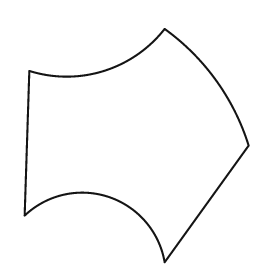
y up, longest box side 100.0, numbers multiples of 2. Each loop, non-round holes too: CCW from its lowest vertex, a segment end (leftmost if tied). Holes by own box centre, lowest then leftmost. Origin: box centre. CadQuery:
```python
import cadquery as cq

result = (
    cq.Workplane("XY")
    .moveTo(12.0, -50.0)
    .lineTo(48.0, 0.0)
    .threePointArc((34.0, 28.0), (12.0, 50.0))
    .threePointArc((-14.0, 32.0), (-46.0, 32.0))
    .lineTo(-48.0, -30.0)
    .threePointArc((-12.0, -22.0), (12.0, -50.0))
    .close()
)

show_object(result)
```